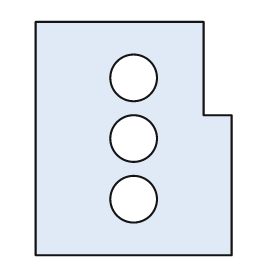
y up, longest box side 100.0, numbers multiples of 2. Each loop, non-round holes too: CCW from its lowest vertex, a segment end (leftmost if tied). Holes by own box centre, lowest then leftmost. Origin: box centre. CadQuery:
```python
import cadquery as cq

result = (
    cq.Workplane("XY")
    .moveTo(-42.0, -50.0)
    .lineTo(42.0, -50.0)
    .lineTo(42.0, 10.0)
    .lineTo(30.0, 10.0)
    .lineTo(30.0, 50.0)
    .lineTo(-42.0, 50.0)
    .close()
    .moveTo(0.0, -26.0)
    .circle(10.0)
    .moveTo(0.0, 0.0)
    .circle(10.0)
    .moveTo(0.0, 26.0)
    .circle(10.0)
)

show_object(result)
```